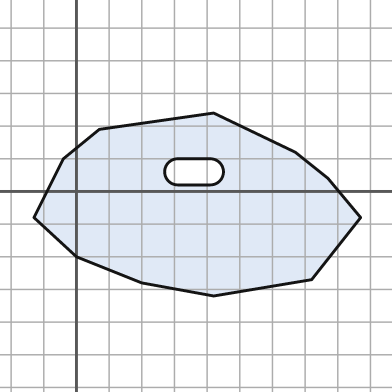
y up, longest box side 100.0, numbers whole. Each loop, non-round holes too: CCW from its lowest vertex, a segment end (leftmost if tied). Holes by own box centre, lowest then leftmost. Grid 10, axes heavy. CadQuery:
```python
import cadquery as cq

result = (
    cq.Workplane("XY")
    .moveTo(42.0, -32.0)
    .lineTo(72.0, -27.0)
    .lineTo(87.0, -8.0)
    .lineTo(77.0, 4.0)
    .lineTo(67.0, 12.0)
    .lineTo(42.0, 24.0)
    .lineTo(7.0, 19.0)
    .lineTo(-4.0, 10.0)
    .lineTo(-13.0, -8.0)
    .lineTo(0.0, -20.0)
    .lineTo(20.0, -28.0)
    .close()
    .moveTo(31.0, 2.0)
    .lineTo(41.0, 2.0)
    .threePointArc((45.0, 6.0), (41.0, 10.0))
    .lineTo(31.0, 10.0)
    .threePointArc((27.0, 6.0), (31.0, 2.0))
    .close()
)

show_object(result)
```